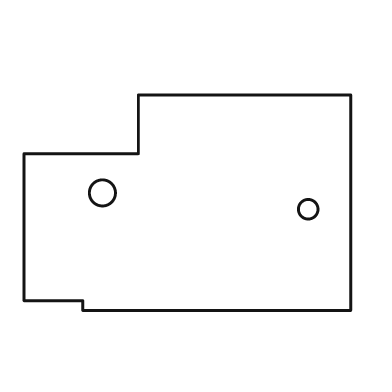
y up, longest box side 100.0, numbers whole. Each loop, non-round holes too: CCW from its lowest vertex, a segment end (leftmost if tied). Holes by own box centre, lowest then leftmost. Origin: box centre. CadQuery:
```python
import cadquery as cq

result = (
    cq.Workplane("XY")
    .moveTo(-32.0, -33.0)
    .lineTo(50.0, -33.0)
    .lineTo(50.0, 33.0)
    .lineTo(-15.0, 33.0)
    .lineTo(-15.0, 15.0)
    .lineTo(-50.0, 15.0)
    .lineTo(-50.0, -30.0)
    .lineTo(-32.0, -30.0)
    .close()
    .moveTo(37.0, -2.0)
    .circle(3.0)
    .moveTo(-26.0, 3.0)
    .circle(4.0)
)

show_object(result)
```